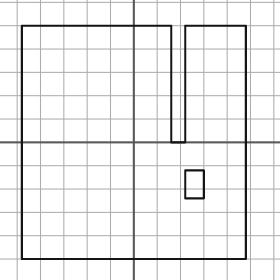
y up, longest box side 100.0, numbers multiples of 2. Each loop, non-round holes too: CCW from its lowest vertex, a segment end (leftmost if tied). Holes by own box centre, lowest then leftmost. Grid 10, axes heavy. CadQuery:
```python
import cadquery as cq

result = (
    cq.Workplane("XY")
    .moveTo(-48.0, -50.0)
    .lineTo(48.0, -50.0)
    .lineTo(48.0, 50.0)
    .lineTo(22.0, 50.0)
    .lineTo(22.0, 0.0)
    .lineTo(16.0, 0.0)
    .lineTo(16.0, 50.0)
    .lineTo(-48.0, 50.0)
    .close()
    .moveTo(22.0, -24.0)
    .lineTo(30.0, -24.0)
    .lineTo(30.0, -12.0)
    .lineTo(22.0, -12.0)
    .close()
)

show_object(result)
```